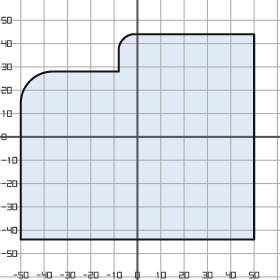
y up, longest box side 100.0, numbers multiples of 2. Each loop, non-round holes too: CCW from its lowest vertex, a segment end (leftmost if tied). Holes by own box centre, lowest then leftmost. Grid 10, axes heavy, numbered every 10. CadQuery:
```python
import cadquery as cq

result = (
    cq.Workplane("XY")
    .moveTo(-50.0, -44.0)
    .lineTo(50.0, -44.0)
    .lineTo(50.0, 44.0)
    .lineTo(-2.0, 44.0)
    .threePointArc((-6.0, 42.0), (-8.0, 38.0))
    .lineTo(-8.0, 28.0)
    .lineTo(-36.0, 28.0)
    .threePointArc((-46.0, 24.0), (-50.0, 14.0))
    .close()
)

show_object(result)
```